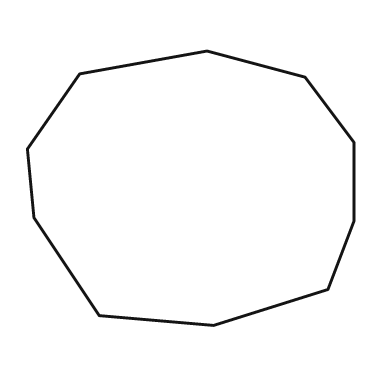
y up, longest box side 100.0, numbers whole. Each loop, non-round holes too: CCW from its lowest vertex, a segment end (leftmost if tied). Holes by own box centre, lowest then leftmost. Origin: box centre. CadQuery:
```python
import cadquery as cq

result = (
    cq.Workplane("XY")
    .moveTo(7.0, -42.0)
    .lineTo(42.0, -31.0)
    .lineTo(50.0, -10.0)
    .lineTo(50.0, 14.0)
    .lineTo(35.0, 34.0)
    .lineTo(5.0, 42.0)
    .lineTo(-34.0, 35.0)
    .lineTo(-50.0, 12.0)
    .lineTo(-48.0, -9.0)
    .lineTo(-28.0, -39.0)
    .close()
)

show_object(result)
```